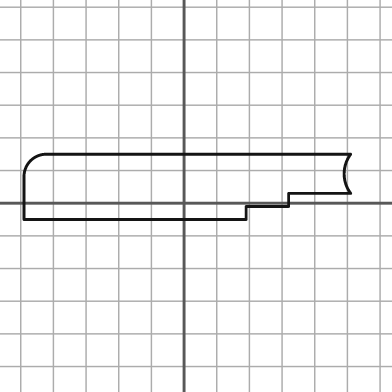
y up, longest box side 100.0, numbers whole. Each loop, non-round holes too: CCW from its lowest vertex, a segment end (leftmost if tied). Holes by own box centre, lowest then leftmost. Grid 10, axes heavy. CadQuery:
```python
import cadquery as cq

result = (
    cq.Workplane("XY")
    .moveTo(-49.0, -5.0)
    .lineTo(19.0, -5.0)
    .lineTo(19.0, -1.0)
    .lineTo(32.0, -1.0)
    .lineTo(32.0, 3.0)
    .lineTo(51.0, 3.0)
    .threePointArc((49.0, 9.0), (51.0, 15.0))
    .lineTo(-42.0, 15.0)
    .threePointArc((-47.0, 13.0), (-49.0, 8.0))
    .close()
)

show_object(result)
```